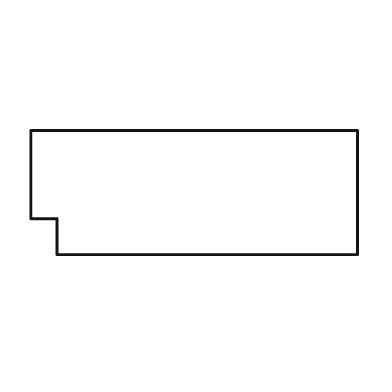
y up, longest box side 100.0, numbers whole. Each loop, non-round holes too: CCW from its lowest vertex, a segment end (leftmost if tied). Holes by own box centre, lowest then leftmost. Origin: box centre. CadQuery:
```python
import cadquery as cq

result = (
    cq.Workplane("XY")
    .moveTo(-42.0, -19.0)
    .lineTo(50.0, -19.0)
    .lineTo(50.0, 19.0)
    .lineTo(-50.0, 19.0)
    .lineTo(-50.0, -8.0)
    .lineTo(-42.0, -8.0)
    .close()
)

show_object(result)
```